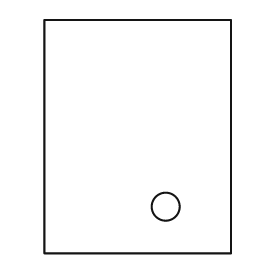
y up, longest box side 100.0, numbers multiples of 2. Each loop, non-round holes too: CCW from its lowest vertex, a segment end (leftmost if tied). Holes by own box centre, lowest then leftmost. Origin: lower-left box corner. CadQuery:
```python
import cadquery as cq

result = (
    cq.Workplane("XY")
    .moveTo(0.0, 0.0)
    .lineTo(80.0, 0.0)
    .lineTo(80.0, 100.0)
    .lineTo(0.0, 100.0)
    .close()
    .moveTo(52.0, 20.0)
    .circle(6.0)
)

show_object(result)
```